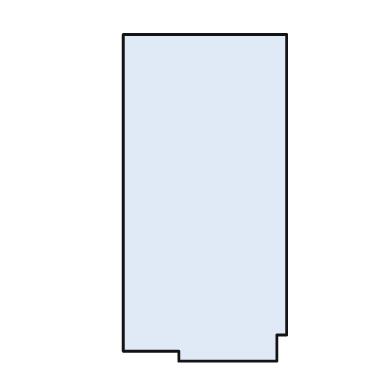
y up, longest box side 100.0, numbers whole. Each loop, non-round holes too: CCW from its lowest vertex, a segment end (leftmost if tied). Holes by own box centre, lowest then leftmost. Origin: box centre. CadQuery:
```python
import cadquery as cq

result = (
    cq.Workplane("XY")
    .moveTo(-8.0, -50.0)
    .lineTo(22.0, -50.0)
    .lineTo(22.0, -42.0)
    .lineTo(25.0, -42.0)
    .lineTo(25.0, 50.0)
    .lineTo(-25.0, 50.0)
    .lineTo(-25.0, -47.0)
    .lineTo(-8.0, -47.0)
    .close()
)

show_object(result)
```